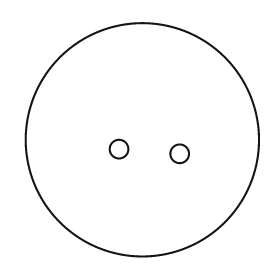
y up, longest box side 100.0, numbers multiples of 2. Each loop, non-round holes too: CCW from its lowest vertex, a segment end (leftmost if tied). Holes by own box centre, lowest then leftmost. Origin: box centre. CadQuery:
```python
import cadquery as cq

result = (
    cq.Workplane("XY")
    .moveTo(0.0, 0.0)
    .circle(50.0)
    .moveTo(16.0, -6.0)
    .circle(4.0)
    .moveTo(-10.0, -4.0)
    .circle(4.0)
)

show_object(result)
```